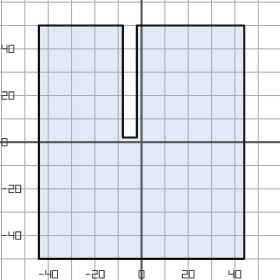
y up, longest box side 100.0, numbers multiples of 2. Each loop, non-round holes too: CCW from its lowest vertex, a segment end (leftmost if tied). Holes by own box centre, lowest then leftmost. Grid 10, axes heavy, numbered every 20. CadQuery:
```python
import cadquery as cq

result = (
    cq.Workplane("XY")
    .moveTo(-44.0, -50.0)
    .lineTo(44.0, -50.0)
    .lineTo(44.0, 50.0)
    .lineTo(-2.0, 50.0)
    .lineTo(-2.0, 2.0)
    .lineTo(-8.0, 2.0)
    .lineTo(-8.0, 50.0)
    .lineTo(-44.0, 50.0)
    .close()
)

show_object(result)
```